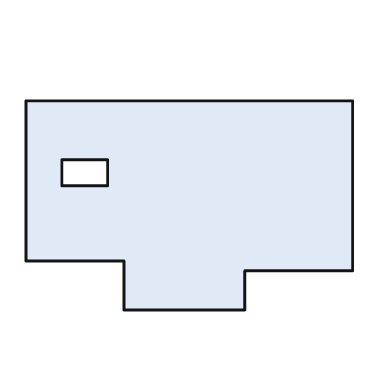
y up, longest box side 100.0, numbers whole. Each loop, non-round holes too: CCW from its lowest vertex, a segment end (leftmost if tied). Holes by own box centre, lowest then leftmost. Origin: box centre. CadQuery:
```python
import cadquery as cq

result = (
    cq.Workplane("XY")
    .moveTo(-20.0, -32.0)
    .lineTo(17.0, -32.0)
    .lineTo(17.0, -20.0)
    .lineTo(50.0, -20.0)
    .lineTo(50.0, 32.0)
    .lineTo(-50.0, 32.0)
    .lineTo(-50.0, -17.0)
    .lineTo(-20.0, -17.0)
    .close()
    .moveTo(-39.0, 6.0)
    .lineTo(-25.0, 6.0)
    .lineTo(-25.0, 14.0)
    .lineTo(-39.0, 14.0)
    .close()
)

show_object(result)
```